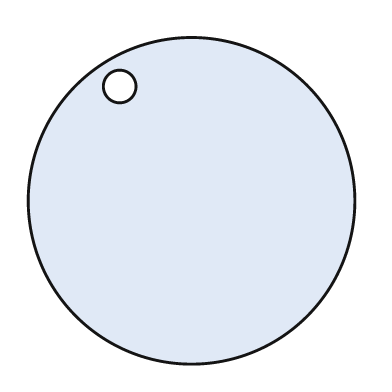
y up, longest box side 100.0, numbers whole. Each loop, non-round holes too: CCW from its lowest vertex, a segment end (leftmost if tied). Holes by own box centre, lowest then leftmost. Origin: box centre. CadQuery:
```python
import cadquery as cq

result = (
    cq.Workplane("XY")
    .moveTo(0.0, 0.0)
    .circle(50.0)
    .moveTo(-22.0, 35.0)
    .circle(5.0)
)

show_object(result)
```